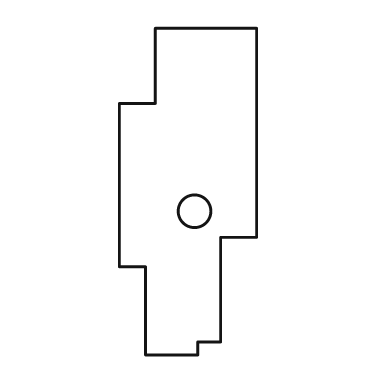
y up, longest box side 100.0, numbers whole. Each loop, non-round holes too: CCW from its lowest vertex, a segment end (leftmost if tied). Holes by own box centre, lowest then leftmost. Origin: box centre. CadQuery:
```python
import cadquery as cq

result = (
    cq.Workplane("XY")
    .moveTo(-13.0, -50.0)
    .lineTo(3.0, -50.0)
    .lineTo(3.0, -46.0)
    .lineTo(10.0, -46.0)
    .lineTo(10.0, -14.0)
    .lineTo(21.0, -14.0)
    .lineTo(21.0, 50.0)
    .lineTo(-10.0, 50.0)
    .lineTo(-10.0, 27.0)
    .lineTo(-21.0, 27.0)
    .lineTo(-21.0, -23.0)
    .lineTo(-13.0, -23.0)
    .close()
    .moveTo(2.0, -6.0)
    .circle(5.0)
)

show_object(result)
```